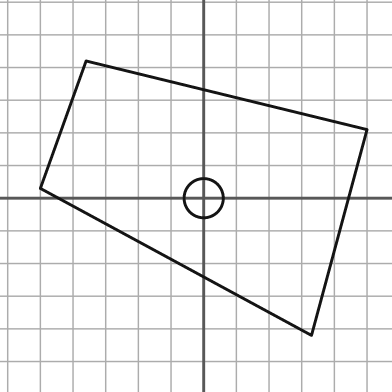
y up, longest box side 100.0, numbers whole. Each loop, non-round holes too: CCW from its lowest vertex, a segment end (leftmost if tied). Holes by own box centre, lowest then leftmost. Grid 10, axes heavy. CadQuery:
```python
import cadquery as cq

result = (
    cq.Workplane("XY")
    .moveTo(33.0, -42.0)
    .lineTo(50.0, 21.0)
    .lineTo(-36.0, 42.0)
    .lineTo(-50.0, 3.0)
    .close()
    .moveTo(0.0, 0.0)
    .circle(6.0)
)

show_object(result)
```